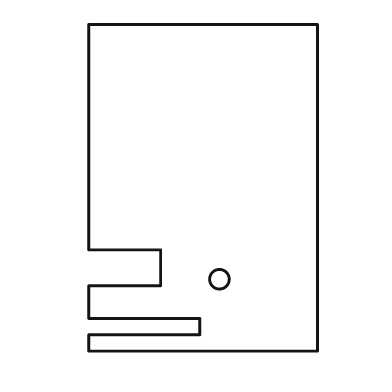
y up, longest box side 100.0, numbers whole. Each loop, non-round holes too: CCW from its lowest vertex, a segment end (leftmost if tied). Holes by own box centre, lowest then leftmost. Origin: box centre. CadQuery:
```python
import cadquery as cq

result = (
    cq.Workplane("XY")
    .moveTo(-35.0, -50.0)
    .lineTo(35.0, -50.0)
    .lineTo(35.0, 50.0)
    .lineTo(-35.0, 50.0)
    .lineTo(-35.0, -19.0)
    .lineTo(-13.0, -19.0)
    .lineTo(-13.0, -30.0)
    .lineTo(-35.0, -30.0)
    .lineTo(-35.0, -40.0)
    .lineTo(-1.0, -40.0)
    .lineTo(-1.0, -45.0)
    .lineTo(-35.0, -45.0)
    .close()
    .moveTo(5.0, -28.0)
    .circle(3.0)
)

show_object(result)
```